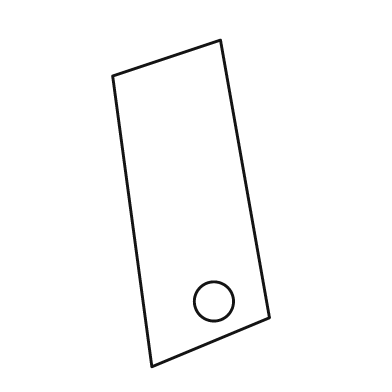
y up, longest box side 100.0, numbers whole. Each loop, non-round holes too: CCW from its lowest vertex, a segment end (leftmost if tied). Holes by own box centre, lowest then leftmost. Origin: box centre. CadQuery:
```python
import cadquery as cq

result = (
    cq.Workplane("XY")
    .moveTo(-12.0, -50.0)
    .lineTo(24.0, -35.0)
    .lineTo(9.0, 50.0)
    .lineTo(-24.0, 39.0)
    .close()
    .moveTo(7.0, -30.0)
    .circle(6.0)
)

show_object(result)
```